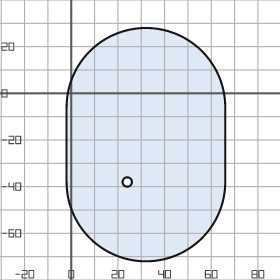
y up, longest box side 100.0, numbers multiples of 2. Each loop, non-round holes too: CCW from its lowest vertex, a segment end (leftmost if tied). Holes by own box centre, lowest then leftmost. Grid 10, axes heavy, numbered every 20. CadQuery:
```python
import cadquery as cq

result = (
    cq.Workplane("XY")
    .moveTo(-2.0, -38.0)
    .threePointArc((32.0, -72.0), (66.0, -38.0))
    .lineTo(66.0, -6.0)
    .threePointArc((32.0, 28.0), (-2.0, -6.0))
    .close()
    .moveTo(24.0, -38.0)
    .circle(2.0)
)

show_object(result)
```